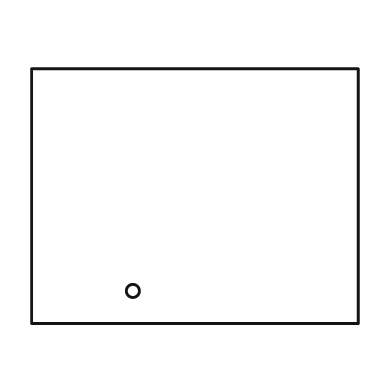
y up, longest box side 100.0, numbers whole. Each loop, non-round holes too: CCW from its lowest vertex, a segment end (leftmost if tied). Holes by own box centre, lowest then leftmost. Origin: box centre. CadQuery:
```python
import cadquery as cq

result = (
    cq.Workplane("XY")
    .moveTo(-50.0, -39.0)
    .lineTo(50.0, -39.0)
    .lineTo(50.0, 39.0)
    .lineTo(-50.0, 39.0)
    .close()
    .moveTo(-19.0, -29.0)
    .circle(2.0)
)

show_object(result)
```